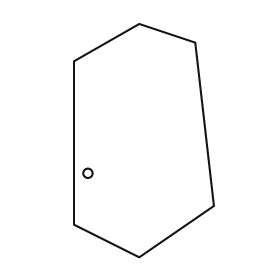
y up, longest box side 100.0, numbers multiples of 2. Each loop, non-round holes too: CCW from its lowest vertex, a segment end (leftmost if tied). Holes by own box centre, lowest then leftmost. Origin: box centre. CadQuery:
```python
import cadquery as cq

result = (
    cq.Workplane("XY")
    .moveTo(-2.0, -50.0)
    .lineTo(30.0, -28.0)
    .lineTo(22.0, 42.0)
    .lineTo(-2.0, 50.0)
    .lineTo(-30.0, 34.0)
    .lineTo(-30.0, -36.0)
    .close()
    .moveTo(-24.0, -14.0)
    .circle(2.0)
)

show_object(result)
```